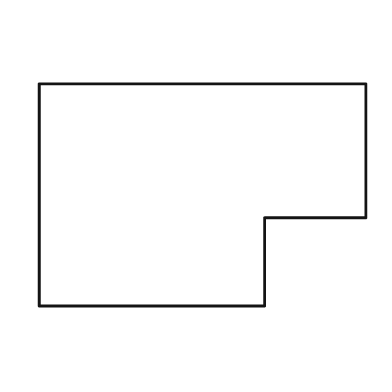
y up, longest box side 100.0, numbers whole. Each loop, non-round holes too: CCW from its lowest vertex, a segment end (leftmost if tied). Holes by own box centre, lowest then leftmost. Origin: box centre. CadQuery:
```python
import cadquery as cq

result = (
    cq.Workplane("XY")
    .moveTo(-50.0, -34.0)
    .lineTo(19.0, -34.0)
    .lineTo(19.0, -7.0)
    .lineTo(50.0, -7.0)
    .lineTo(50.0, 34.0)
    .lineTo(-50.0, 34.0)
    .close()
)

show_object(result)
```